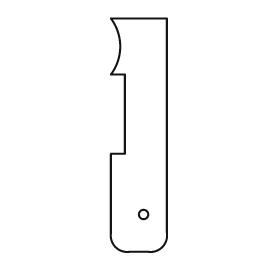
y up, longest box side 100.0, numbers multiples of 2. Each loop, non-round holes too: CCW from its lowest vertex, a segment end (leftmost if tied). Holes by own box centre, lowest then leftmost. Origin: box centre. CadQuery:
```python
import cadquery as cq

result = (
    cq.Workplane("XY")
    .moveTo(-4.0, -50.0)
    .lineTo(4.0, -50.0)
    .threePointArc((10.0, -48.0), (12.0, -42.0))
    .lineTo(12.0, 50.0)
    .lineTo(-12.0, 50.0)
    .threePointArc((-8.0, 38.0), (-12.0, 26.0))
    .lineTo(-6.0, 26.0)
    .lineTo(-6.0, -8.0)
    .lineTo(-12.0, -8.0)
    .lineTo(-12.0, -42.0)
    .threePointArc((-10.0, -48.0), (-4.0, -50.0))
    .close()
    .moveTo(2.0, -34.0)
    .circle(2.0)
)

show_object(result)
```